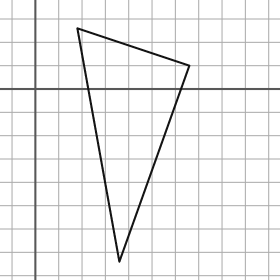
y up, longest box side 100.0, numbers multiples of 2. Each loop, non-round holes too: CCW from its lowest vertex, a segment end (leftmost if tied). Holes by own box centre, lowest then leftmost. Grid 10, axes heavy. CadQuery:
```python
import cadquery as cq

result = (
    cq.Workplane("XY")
    .moveTo(36.0, -74.0)
    .lineTo(66.0, 10.0)
    .lineTo(18.0, 26.0)
    .close()
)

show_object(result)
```